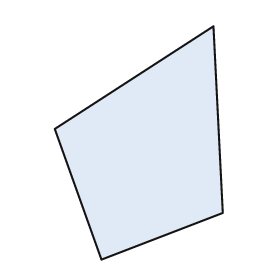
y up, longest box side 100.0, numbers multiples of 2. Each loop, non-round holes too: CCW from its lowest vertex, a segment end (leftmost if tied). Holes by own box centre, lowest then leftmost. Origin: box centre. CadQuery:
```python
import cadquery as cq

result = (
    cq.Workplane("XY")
    .moveTo(-16.0, -50.0)
    .lineTo(36.0, -30.0)
    .lineTo(32.0, 50.0)
    .lineTo(-36.0, 6.0)
    .close()
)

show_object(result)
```